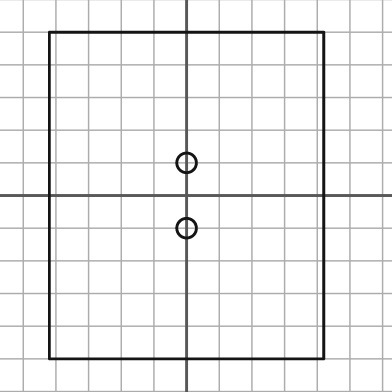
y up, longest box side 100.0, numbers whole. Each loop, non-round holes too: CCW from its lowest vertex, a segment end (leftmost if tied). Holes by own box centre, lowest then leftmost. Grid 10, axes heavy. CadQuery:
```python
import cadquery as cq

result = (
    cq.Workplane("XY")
    .moveTo(-42.0, -50.0)
    .lineTo(42.0, -50.0)
    .lineTo(42.0, 50.0)
    .lineTo(-42.0, 50.0)
    .close()
    .moveTo(0.0, -10.0)
    .circle(3.0)
    .moveTo(0.0, 10.0)
    .circle(3.0)
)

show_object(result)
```